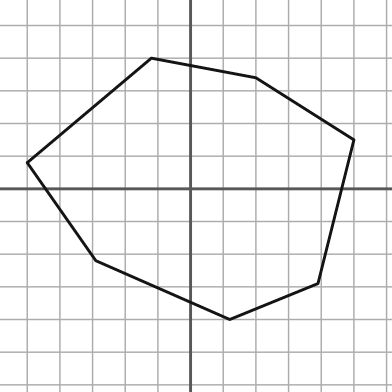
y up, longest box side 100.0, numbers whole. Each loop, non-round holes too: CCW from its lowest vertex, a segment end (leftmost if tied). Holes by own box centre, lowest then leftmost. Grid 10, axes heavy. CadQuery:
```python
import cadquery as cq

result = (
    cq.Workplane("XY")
    .moveTo(12.0, -40.0)
    .lineTo(39.0, -29.0)
    .lineTo(50.0, 15.0)
    .lineTo(20.0, 34.0)
    .lineTo(-12.0, 40.0)
    .lineTo(-50.0, 8.0)
    .lineTo(-29.0, -22.0)
    .close()
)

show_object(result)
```